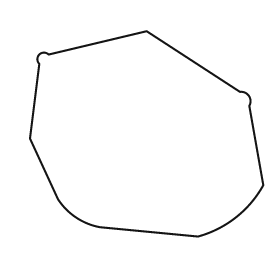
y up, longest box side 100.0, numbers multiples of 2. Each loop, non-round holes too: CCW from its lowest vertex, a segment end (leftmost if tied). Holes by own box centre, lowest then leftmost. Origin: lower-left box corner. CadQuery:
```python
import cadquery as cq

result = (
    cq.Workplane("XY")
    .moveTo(72.0, 0.0)
    .threePointArc((88.0, 8.0), (100.0, 22.0))
    .lineTo(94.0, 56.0)
    .threePointArc((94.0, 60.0), (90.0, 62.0))
    .lineTo(50.0, 88.0)
    .lineTo(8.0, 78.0)
    .threePointArc((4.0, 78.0), (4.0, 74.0))
    .lineTo(0.0, 42.0)
    .lineTo(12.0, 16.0)
    .threePointArc((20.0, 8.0), (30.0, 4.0))
    .close()
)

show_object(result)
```